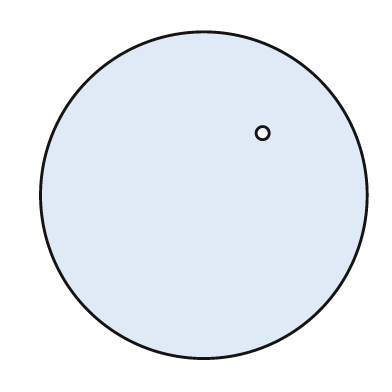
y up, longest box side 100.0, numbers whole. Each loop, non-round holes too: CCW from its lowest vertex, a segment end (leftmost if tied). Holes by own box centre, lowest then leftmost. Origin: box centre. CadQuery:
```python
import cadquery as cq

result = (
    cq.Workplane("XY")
    .moveTo(0.0, 0.0)
    .circle(50.0)
    .moveTo(18.0, 19.0)
    .circle(2.0)
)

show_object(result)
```